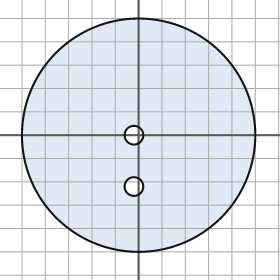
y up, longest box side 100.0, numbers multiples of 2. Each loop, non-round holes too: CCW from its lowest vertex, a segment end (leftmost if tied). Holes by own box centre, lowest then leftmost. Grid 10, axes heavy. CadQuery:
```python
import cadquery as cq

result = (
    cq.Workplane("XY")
    .moveTo(0.0, 0.0)
    .circle(50.0)
    .moveTo(-2.0, -22.0)
    .circle(4.0)
    .moveTo(-2.0, 0.0)
    .circle(4.0)
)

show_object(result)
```